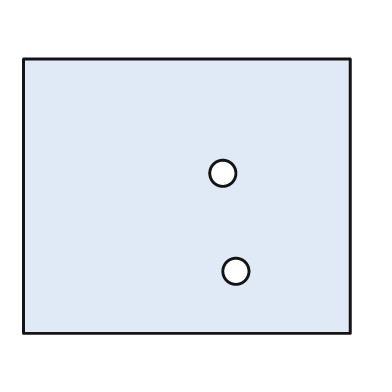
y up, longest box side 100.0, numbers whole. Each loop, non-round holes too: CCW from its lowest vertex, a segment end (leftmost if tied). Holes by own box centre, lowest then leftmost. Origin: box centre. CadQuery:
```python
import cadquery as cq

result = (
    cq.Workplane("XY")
    .moveTo(-50.0, -42.0)
    .lineTo(50.0, -42.0)
    .lineTo(50.0, 42.0)
    .lineTo(-50.0, 42.0)
    .close()
    .moveTo(15.0, -23.0)
    .circle(4.0)
    .moveTo(11.0, 7.0)
    .circle(4.0)
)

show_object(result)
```